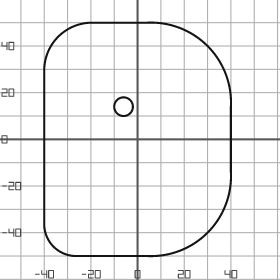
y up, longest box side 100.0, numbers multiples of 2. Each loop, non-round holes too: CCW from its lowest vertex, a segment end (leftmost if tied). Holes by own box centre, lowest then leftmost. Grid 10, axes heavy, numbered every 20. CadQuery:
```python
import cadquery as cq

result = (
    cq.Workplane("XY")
    .moveTo(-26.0, -50.0)
    .lineTo(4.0, -50.0)
    .threePointArc((30.0, -40.0), (40.0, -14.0))
    .lineTo(40.0, 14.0)
    .threePointArc((30.0, 40.0), (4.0, 50.0))
    .lineTo(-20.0, 50.0)
    .threePointArc((-34.0, 44.0), (-40.0, 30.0))
    .lineTo(-40.0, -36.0)
    .threePointArc((-36.0, -46.0), (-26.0, -50.0))
    .close()
    .moveTo(-6.0, 14.0)
    .circle(4.0)
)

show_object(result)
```